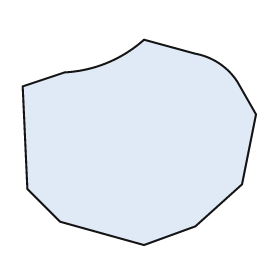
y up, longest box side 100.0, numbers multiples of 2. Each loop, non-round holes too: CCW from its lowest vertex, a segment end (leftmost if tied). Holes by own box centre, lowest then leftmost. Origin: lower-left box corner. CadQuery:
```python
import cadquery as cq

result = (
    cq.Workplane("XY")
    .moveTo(52.0, 0.0)
    .lineTo(74.0, 8.0)
    .lineTo(94.0, 26.0)
    .lineTo(100.0, 56.0)
    .lineTo(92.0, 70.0)
    .threePointArc((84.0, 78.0), (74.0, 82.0))
    .lineTo(52.0, 88.0)
    .threePointArc((36.0, 78.0), (18.0, 74.0))
    .lineTo(0.0, 68.0)
    .lineTo(2.0, 24.0)
    .lineTo(16.0, 10.0)
    .close()
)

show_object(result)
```